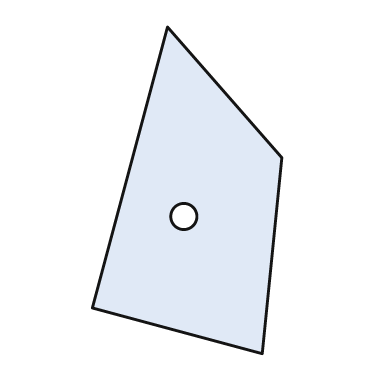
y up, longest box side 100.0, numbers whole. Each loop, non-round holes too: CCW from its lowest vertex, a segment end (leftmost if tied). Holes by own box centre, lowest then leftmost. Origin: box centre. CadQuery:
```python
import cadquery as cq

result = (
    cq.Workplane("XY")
    .moveTo(23.0, -50.0)
    .lineTo(29.0, 10.0)
    .lineTo(-6.0, 50.0)
    .lineTo(-29.0, -36.0)
    .close()
    .moveTo(-1.0, -8.0)
    .circle(4.0)
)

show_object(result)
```